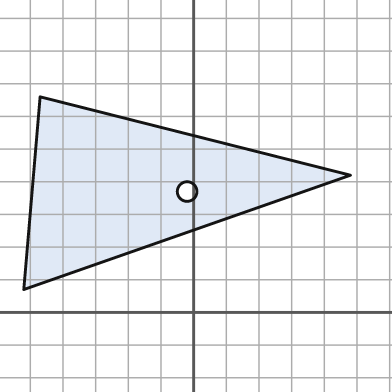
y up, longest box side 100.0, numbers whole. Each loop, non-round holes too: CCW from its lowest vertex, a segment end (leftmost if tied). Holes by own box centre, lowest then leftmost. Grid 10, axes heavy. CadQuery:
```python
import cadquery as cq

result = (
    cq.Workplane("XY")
    .moveTo(-52.0, 7.0)
    .lineTo(48.0, 42.0)
    .lineTo(-47.0, 66.0)
    .close()
    .moveTo(-2.0, 37.0)
    .circle(3.0)
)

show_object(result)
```